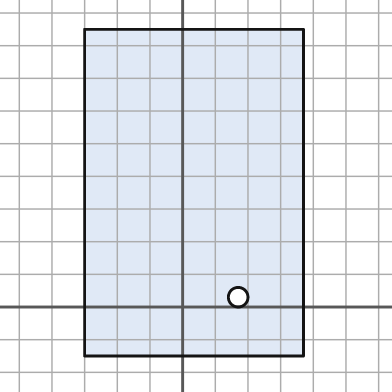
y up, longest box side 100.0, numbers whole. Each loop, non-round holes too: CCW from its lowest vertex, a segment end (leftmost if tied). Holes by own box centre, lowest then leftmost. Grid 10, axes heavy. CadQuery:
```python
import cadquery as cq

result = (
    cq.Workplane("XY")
    .moveTo(-30.0, -15.0)
    .lineTo(37.0, -15.0)
    .lineTo(37.0, 85.0)
    .lineTo(-30.0, 85.0)
    .close()
    .moveTo(17.0, 3.0)
    .circle(3.0)
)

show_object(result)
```